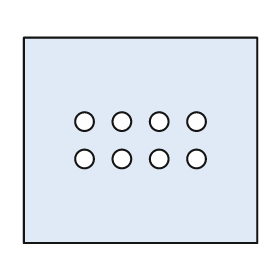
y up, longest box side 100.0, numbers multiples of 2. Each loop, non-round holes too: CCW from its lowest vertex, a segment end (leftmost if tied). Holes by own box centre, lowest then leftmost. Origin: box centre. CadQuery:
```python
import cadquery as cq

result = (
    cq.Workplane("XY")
    .moveTo(-50.0, -44.0)
    .lineTo(50.0, -44.0)
    .lineTo(50.0, 44.0)
    .lineTo(-50.0, 44.0)
    .close()
    .moveTo(-24.0, -8.0)
    .circle(4.0)
    .moveTo(-8.0, -8.0)
    .circle(4.0)
    .moveTo(8.0, -8.0)
    .circle(4.0)
    .moveTo(24.0, -8.0)
    .circle(4.0)
    .moveTo(-24.0, 8.0)
    .circle(4.0)
    .moveTo(-8.0, 8.0)
    .circle(4.0)
    .moveTo(8.0, 8.0)
    .circle(4.0)
    .moveTo(24.0, 8.0)
    .circle(4.0)
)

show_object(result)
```